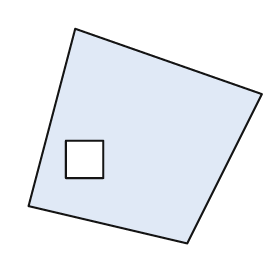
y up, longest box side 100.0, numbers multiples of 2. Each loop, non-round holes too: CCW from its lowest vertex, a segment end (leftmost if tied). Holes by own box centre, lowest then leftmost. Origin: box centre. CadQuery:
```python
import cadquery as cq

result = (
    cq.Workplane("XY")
    .moveTo(18.0, -46.0)
    .lineTo(50.0, 18.0)
    .lineTo(-30.0, 46.0)
    .lineTo(-50.0, -30.0)
    .close()
    .moveTo(-34.0, -18.0)
    .lineTo(-18.0, -18.0)
    .lineTo(-18.0, -2.0)
    .lineTo(-34.0, -2.0)
    .close()
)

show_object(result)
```